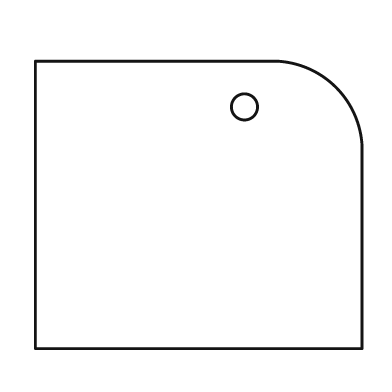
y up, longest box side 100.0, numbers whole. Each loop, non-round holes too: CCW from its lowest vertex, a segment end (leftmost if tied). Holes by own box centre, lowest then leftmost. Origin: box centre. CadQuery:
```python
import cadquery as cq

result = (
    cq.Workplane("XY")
    .moveTo(-50.0, -44.0)
    .lineTo(50.0, -44.0)
    .lineTo(50.0, 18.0)
    .threePointArc((42.0, 36.0), (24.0, 44.0))
    .lineTo(-50.0, 44.0)
    .close()
    .moveTo(14.0, 30.0)
    .circle(4.0)
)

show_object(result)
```